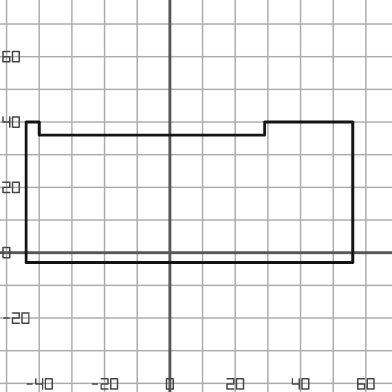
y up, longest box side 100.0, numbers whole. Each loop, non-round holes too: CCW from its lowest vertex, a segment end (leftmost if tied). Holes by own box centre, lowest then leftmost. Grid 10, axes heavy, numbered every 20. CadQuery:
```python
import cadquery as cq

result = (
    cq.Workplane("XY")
    .moveTo(-44.0, -3.0)
    .lineTo(56.0, -3.0)
    .lineTo(56.0, 40.0)
    .lineTo(29.0, 40.0)
    .lineTo(29.0, 36.0)
    .lineTo(-40.0, 36.0)
    .lineTo(-40.0, 40.0)
    .lineTo(-44.0, 40.0)
    .close()
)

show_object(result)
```